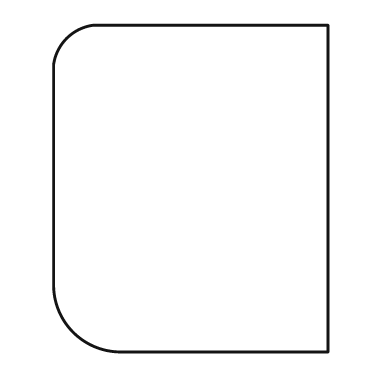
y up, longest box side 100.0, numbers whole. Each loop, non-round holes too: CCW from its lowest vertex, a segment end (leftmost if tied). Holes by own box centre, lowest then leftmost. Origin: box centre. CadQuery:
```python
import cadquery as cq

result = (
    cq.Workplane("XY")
    .moveTo(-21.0, -50.0)
    .lineTo(42.0, -50.0)
    .lineTo(42.0, 50.0)
    .lineTo(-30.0, 50.0)
    .threePointArc((-38.0, 46.0), (-42.0, 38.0))
    .lineTo(-42.0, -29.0)
    .threePointArc((-36.0, -44.0), (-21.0, -50.0))
    .close()
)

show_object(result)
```